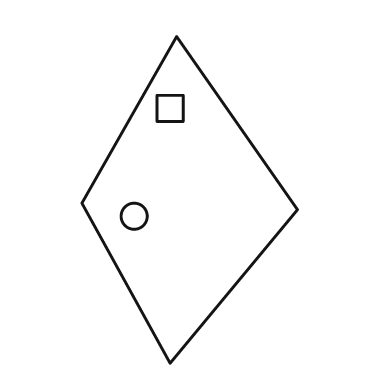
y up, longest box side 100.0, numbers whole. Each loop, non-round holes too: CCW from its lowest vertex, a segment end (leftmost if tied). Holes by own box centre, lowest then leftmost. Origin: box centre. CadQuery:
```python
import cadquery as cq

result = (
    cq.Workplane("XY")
    .moveTo(-6.0, -50.0)
    .lineTo(33.0, -3.0)
    .lineTo(-4.0, 50.0)
    .lineTo(-33.0, -1.0)
    .close()
    .moveTo(-17.0, -5.0)
    .circle(4.0)
    .moveTo(-10.0, 24.0)
    .lineTo(-2.0, 24.0)
    .lineTo(-2.0, 32.0)
    .lineTo(-10.0, 32.0)
    .close()
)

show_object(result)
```